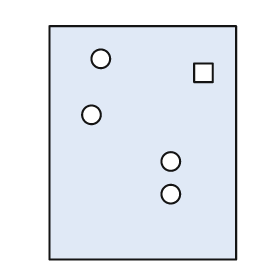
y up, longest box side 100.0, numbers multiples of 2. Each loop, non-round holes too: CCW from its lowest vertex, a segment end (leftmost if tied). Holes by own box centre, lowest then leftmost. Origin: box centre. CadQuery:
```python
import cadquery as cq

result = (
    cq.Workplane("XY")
    .moveTo(-40.0, -50.0)
    .lineTo(40.0, -50.0)
    .lineTo(40.0, 50.0)
    .lineTo(-40.0, 50.0)
    .close()
    .moveTo(12.0, -22.0)
    .circle(4.0)
    .moveTo(12.0, -8.0)
    .circle(4.0)
    .moveTo(-22.0, 12.0)
    .circle(4.0)
    .moveTo(22.0, 26.0)
    .lineTo(30.0, 26.0)
    .lineTo(30.0, 34.0)
    .lineTo(22.0, 34.0)
    .close()
    .moveTo(-18.0, 36.0)
    .circle(4.0)
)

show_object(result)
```